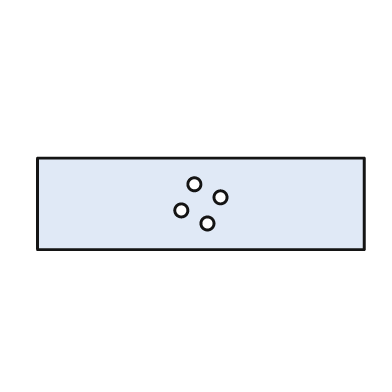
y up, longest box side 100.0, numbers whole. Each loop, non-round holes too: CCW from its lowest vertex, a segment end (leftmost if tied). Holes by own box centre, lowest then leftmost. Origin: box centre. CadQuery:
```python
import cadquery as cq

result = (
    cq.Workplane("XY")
    .moveTo(-50.0, -14.0)
    .lineTo(50.0, -14.0)
    .lineTo(50.0, 14.0)
    .lineTo(-50.0, 14.0)
    .close()
    .moveTo(2.0, -6.0)
    .circle(2.0)
    .moveTo(-6.0, -2.0)
    .circle(2.0)
    .moveTo(6.0, 2.0)
    .circle(2.0)
    .moveTo(-2.0, 6.0)
    .circle(2.0)
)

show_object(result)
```